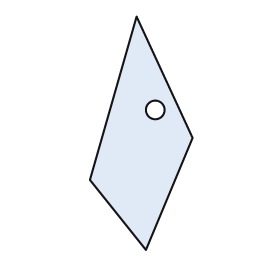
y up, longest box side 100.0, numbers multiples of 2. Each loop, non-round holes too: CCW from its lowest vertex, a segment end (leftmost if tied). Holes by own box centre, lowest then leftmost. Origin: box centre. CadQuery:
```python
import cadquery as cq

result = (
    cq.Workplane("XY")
    .moveTo(2.0, -50.0)
    .lineTo(22.0, -2.0)
    .lineTo(-2.0, 50.0)
    .lineTo(-22.0, -20.0)
    .close()
    .moveTo(6.0, 10.0)
    .circle(4.0)
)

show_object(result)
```